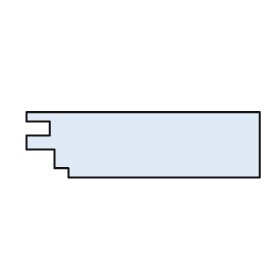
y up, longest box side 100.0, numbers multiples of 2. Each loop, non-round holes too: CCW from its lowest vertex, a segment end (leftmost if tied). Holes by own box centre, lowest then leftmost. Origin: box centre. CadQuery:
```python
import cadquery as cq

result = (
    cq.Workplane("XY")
    .moveTo(-32.0, -14.0)
    .lineTo(50.0, -14.0)
    .lineTo(50.0, 14.0)
    .lineTo(-50.0, 14.0)
    .lineTo(-50.0, 10.0)
    .lineTo(-40.0, 10.0)
    .lineTo(-40.0, 4.0)
    .lineTo(-50.0, 4.0)
    .lineTo(-50.0, -2.0)
    .lineTo(-38.0, -2.0)
    .lineTo(-38.0, -10.0)
    .lineTo(-32.0, -10.0)
    .close()
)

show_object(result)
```